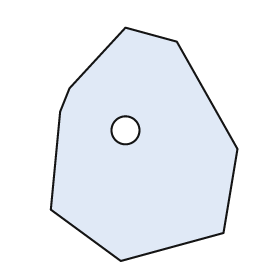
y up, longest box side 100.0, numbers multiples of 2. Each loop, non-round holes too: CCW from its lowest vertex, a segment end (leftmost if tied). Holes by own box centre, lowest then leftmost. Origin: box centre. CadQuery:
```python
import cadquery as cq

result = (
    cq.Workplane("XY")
    .moveTo(-10.0, -50.0)
    .lineTo(34.0, -38.0)
    .lineTo(40.0, -2.0)
    .lineTo(14.0, 44.0)
    .lineTo(-8.0, 50.0)
    .lineTo(-32.0, 24.0)
    .lineTo(-36.0, 14.0)
    .lineTo(-40.0, -28.0)
    .close()
    .moveTo(-8.0, 6.0)
    .circle(6.0)
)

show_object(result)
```